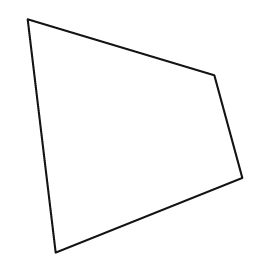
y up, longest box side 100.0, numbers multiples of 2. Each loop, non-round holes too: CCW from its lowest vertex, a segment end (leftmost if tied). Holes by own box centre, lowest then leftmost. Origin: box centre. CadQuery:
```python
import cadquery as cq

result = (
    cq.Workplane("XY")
    .moveTo(-34.0, -50.0)
    .lineTo(46.0, -18.0)
    .lineTo(34.0, 26.0)
    .lineTo(-46.0, 50.0)
    .close()
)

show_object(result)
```